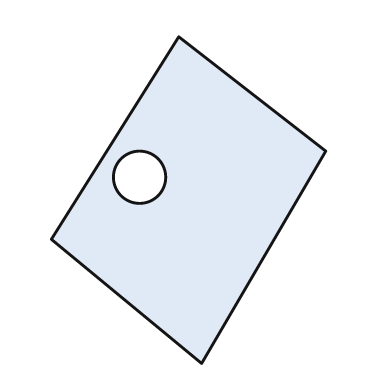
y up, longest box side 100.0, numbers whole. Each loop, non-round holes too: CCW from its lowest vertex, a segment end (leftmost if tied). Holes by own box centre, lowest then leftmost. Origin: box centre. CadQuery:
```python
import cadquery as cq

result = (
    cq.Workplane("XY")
    .moveTo(4.0, -50.0)
    .lineTo(42.0, 15.0)
    .lineTo(-3.0, 50.0)
    .lineTo(-42.0, -12.0)
    .close()
    .moveTo(-15.0, 7.0)
    .circle(8.0)
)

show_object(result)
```